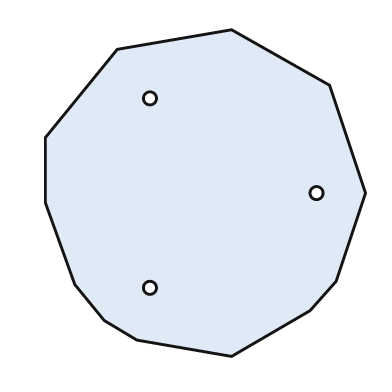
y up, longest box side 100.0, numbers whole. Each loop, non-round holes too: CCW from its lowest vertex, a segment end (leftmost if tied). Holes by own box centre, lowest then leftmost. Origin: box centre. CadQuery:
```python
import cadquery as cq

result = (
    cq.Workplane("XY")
    .moveTo(8.0, -50.0)
    .lineTo(32.0, -36.0)
    .lineTo(40.0, -27.0)
    .lineTo(49.0, 0.0)
    .lineTo(38.0, 33.0)
    .lineTo(8.0, 50.0)
    .lineTo(-27.0, 44.0)
    .lineTo(-49.0, 17.0)
    .lineTo(-49.0, -3.0)
    .lineTo(-40.0, -28.0)
    .lineTo(-31.0, -39.0)
    .lineTo(-21.0, -45.0)
    .close()
    .moveTo(-17.0, -29.0)
    .circle(2.0)
    .moveTo(34.0, 0.0)
    .circle(2.0)
    .moveTo(-17.0, 29.0)
    .circle(2.0)
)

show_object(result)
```